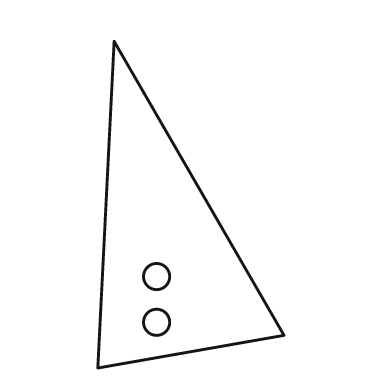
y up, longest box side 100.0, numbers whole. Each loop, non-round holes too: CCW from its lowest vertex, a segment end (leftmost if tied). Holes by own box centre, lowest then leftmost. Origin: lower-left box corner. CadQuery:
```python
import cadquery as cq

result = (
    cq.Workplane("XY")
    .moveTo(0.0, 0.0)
    .lineTo(57.0, 10.0)
    .lineTo(5.0, 100.0)
    .close()
    .moveTo(18.0, 14.0)
    .circle(4.0)
    .moveTo(18.0, 28.0)
    .circle(4.0)
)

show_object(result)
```